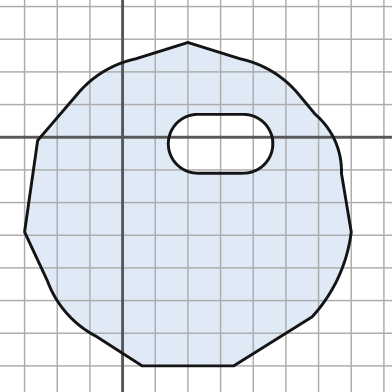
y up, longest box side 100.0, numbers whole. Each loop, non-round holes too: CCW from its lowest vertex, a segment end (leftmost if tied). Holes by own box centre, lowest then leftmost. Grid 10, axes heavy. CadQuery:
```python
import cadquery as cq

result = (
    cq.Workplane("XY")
    .moveTo(6.0, -70.0)
    .lineTo(34.0, -70.0)
    .lineTo(58.0, -55.0)
    .threePointArc((66.0, -43.0), (70.0, -29.0))
    .lineTo(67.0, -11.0)
    .threePointArc((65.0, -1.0), (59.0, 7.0))
    .lineTo(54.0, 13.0)
    .threePointArc((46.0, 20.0), (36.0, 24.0))
    .lineTo(20.0, 29.0)
    .lineTo(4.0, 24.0)
    .threePointArc((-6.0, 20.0), (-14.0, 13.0))
    .lineTo(-26.0, -1.0)
    .lineTo(-30.0, -29.0)
    .lineTo(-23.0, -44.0)
    .threePointArc((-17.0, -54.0), (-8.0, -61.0))
    .close()
    .moveTo(23.0, -11.0)
    .lineTo(37.0, -11.0)
    .threePointArc((46.0, -2.0), (37.0, 7.0))
    .lineTo(23.0, 7.0)
    .threePointArc((14.0, -2.0), (23.0, -11.0))
    .close()
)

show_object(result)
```